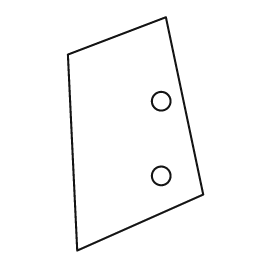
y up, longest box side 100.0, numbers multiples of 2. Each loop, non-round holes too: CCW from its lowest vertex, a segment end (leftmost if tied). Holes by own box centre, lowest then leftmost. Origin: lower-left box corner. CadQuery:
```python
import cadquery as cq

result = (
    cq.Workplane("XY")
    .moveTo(4.0, 0.0)
    .lineTo(58.0, 24.0)
    .lineTo(42.0, 100.0)
    .lineTo(0.0, 84.0)
    .close()
    .moveTo(40.0, 32.0)
    .circle(4.0)
    .moveTo(40.0, 64.0)
    .circle(4.0)
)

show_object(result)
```